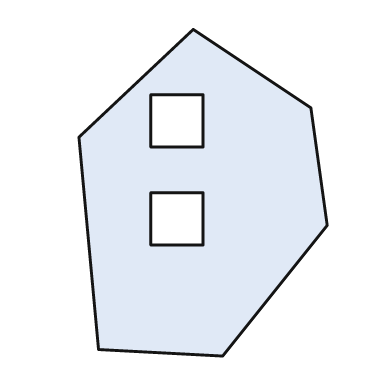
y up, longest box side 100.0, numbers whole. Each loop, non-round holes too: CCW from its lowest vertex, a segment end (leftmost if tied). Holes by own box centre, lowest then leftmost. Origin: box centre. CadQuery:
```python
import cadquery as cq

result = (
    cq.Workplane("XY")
    .moveTo(6.0, -50.0)
    .lineTo(38.0, -10.0)
    .lineTo(33.0, 26.0)
    .lineTo(-3.0, 50.0)
    .lineTo(-38.0, 17.0)
    .lineTo(-32.0, -48.0)
    .close()
    .moveTo(-16.0, -16.0)
    .lineTo(0.0, -16.0)
    .lineTo(0.0, 0.0)
    .lineTo(-16.0, 0.0)
    .close()
    .moveTo(-16.0, 14.0)
    .lineTo(0.0, 14.0)
    .lineTo(0.0, 30.0)
    .lineTo(-16.0, 30.0)
    .close()
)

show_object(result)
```